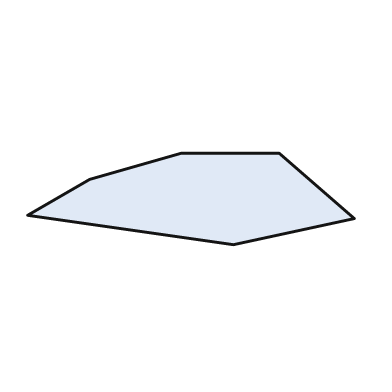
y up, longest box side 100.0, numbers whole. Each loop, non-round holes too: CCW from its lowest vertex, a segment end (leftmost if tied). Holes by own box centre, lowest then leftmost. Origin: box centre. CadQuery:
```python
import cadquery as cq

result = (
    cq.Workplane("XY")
    .moveTo(13.0, -14.0)
    .lineTo(50.0, -6.0)
    .lineTo(27.0, 14.0)
    .lineTo(-3.0, 14.0)
    .lineTo(-31.0, 6.0)
    .lineTo(-50.0, -5.0)
    .close()
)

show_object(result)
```